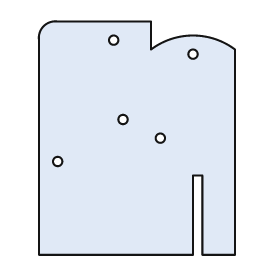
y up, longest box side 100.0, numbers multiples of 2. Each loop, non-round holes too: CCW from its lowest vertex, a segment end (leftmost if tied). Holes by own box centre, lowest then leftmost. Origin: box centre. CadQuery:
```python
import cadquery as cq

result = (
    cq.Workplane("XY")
    .moveTo(-42.0, -50.0)
    .lineTo(24.0, -50.0)
    .lineTo(24.0, -16.0)
    .lineTo(28.0, -16.0)
    .lineTo(28.0, -50.0)
    .lineTo(42.0, -50.0)
    .lineTo(42.0, 38.0)
    .threePointArc((24.0, 44.0), (6.0, 38.0))
    .lineTo(6.0, 50.0)
    .lineTo(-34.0, 50.0)
    .threePointArc((-40.0, 48.0), (-42.0, 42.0))
    .close()
    .moveTo(-34.0, -10.0)
    .circle(2.0)
    .moveTo(10.0, 0.0)
    .circle(2.0)
    .moveTo(-6.0, 8.0)
    .circle(2.0)
    .moveTo(24.0, 36.0)
    .circle(2.0)
    .moveTo(-10.0, 42.0)
    .circle(2.0)
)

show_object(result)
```